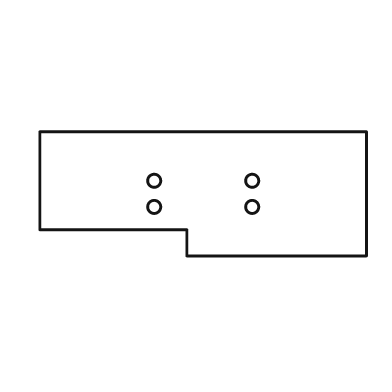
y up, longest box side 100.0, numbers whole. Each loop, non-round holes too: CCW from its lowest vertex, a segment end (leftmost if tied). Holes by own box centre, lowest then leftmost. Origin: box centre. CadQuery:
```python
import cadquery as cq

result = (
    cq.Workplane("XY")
    .moveTo(-5.0, -19.0)
    .lineTo(50.0, -19.0)
    .lineTo(50.0, 19.0)
    .lineTo(-50.0, 19.0)
    .lineTo(-50.0, -11.0)
    .lineTo(-5.0, -11.0)
    .close()
    .moveTo(-15.0, -4.0)
    .circle(2.0)
    .moveTo(15.0, -4.0)
    .circle(2.0)
    .moveTo(-15.0, 4.0)
    .circle(2.0)
    .moveTo(15.0, 4.0)
    .circle(2.0)
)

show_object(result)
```